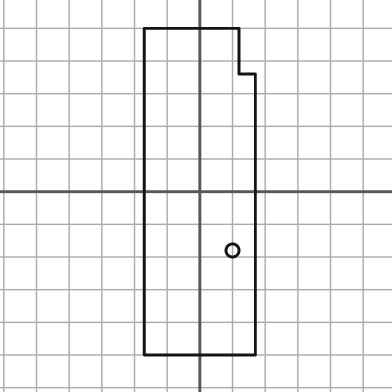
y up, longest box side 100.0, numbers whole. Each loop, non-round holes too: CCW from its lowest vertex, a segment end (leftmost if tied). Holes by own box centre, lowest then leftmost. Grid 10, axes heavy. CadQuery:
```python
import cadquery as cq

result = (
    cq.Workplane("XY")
    .moveTo(-17.0, -50.0)
    .lineTo(17.0, -50.0)
    .lineTo(17.0, 36.0)
    .lineTo(12.0, 36.0)
    .lineTo(12.0, 50.0)
    .lineTo(-17.0, 50.0)
    .close()
    .moveTo(10.0, -18.0)
    .circle(2.0)
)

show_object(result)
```